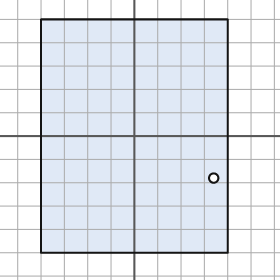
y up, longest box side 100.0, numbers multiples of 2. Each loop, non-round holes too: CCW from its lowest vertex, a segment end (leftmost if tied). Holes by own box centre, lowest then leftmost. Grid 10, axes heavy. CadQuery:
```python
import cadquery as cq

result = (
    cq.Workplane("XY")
    .moveTo(-40.0, -50.0)
    .lineTo(40.0, -50.0)
    .lineTo(40.0, 50.0)
    .lineTo(-40.0, 50.0)
    .close()
    .moveTo(34.0, -18.0)
    .circle(2.0)
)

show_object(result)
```